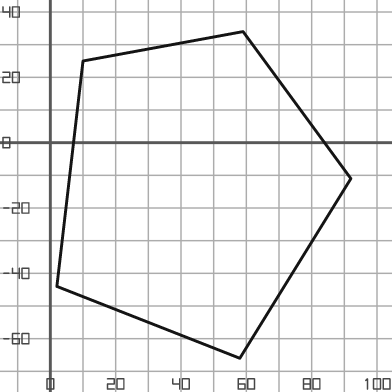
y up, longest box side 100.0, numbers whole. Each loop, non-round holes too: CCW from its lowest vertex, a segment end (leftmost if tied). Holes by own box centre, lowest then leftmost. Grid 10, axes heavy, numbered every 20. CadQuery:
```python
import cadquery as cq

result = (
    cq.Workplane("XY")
    .moveTo(58.0, -66.0)
    .lineTo(92.0, -11.0)
    .lineTo(59.0, 34.0)
    .lineTo(10.0, 25.0)
    .lineTo(2.0, -44.0)
    .close()
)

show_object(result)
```